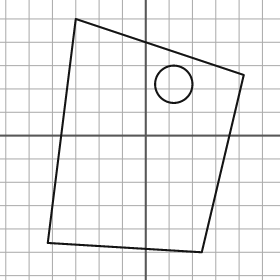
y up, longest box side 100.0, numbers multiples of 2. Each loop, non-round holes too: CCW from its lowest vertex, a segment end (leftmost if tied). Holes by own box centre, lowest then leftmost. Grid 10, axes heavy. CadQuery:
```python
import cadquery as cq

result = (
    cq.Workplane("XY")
    .moveTo(24.0, -50.0)
    .lineTo(42.0, 26.0)
    .lineTo(-30.0, 50.0)
    .lineTo(-42.0, -46.0)
    .close()
    .moveTo(12.0, 22.0)
    .circle(8.0)
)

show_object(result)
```